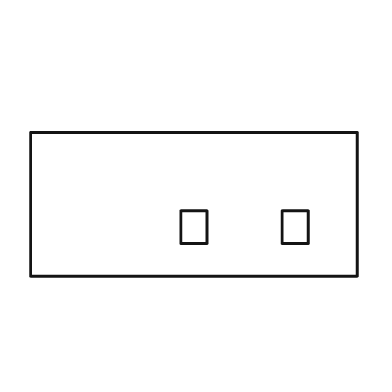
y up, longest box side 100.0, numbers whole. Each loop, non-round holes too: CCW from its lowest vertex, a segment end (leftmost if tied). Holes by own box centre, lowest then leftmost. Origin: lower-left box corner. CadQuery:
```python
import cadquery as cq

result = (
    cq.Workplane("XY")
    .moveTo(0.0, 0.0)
    .lineTo(100.0, 0.0)
    .lineTo(100.0, 44.0)
    .lineTo(0.0, 44.0)
    .close()
    .moveTo(46.0, 10.0)
    .lineTo(54.0, 10.0)
    .lineTo(54.0, 20.0)
    .lineTo(46.0, 20.0)
    .close()
    .moveTo(77.0, 10.0)
    .lineTo(85.0, 10.0)
    .lineTo(85.0, 20.0)
    .lineTo(77.0, 20.0)
    .close()
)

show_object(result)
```